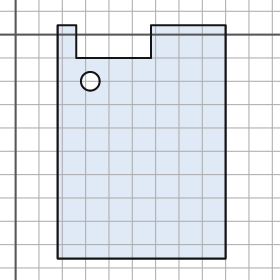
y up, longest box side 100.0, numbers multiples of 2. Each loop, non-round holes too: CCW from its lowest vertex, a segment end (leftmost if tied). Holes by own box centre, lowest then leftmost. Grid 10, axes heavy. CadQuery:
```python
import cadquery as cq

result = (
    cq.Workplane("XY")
    .moveTo(18.0, -96.0)
    .lineTo(90.0, -96.0)
    .lineTo(90.0, 4.0)
    .lineTo(58.0, 4.0)
    .lineTo(58.0, -10.0)
    .lineTo(26.0, -10.0)
    .lineTo(26.0, 4.0)
    .lineTo(18.0, 4.0)
    .close()
    .moveTo(32.0, -20.0)
    .circle(4.0)
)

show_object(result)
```